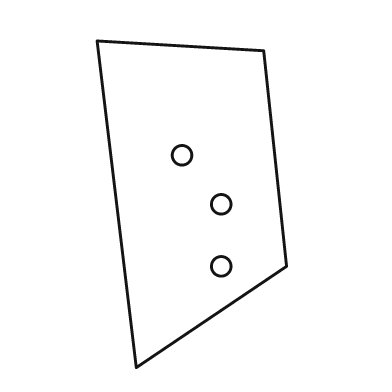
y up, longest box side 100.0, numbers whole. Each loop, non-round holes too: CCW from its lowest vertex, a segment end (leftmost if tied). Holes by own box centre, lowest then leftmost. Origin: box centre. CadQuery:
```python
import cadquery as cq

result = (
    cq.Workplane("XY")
    .moveTo(-17.0, -50.0)
    .lineTo(29.0, -19.0)
    .lineTo(22.0, 47.0)
    .lineTo(-29.0, 50.0)
    .close()
    .moveTo(9.0, -19.0)
    .circle(3.0)
    .moveTo(9.0, 0.0)
    .circle(3.0)
    .moveTo(-3.0, 15.0)
    .circle(3.0)
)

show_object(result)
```